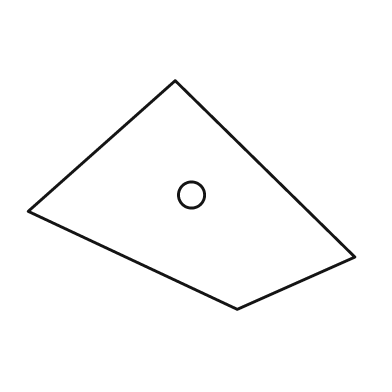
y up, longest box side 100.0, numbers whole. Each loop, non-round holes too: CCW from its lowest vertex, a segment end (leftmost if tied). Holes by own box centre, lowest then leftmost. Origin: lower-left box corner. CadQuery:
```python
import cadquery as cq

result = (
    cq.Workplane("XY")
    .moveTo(64.0, 0.0)
    .lineTo(100.0, 16.0)
    .lineTo(45.0, 70.0)
    .lineTo(0.0, 30.0)
    .close()
    .moveTo(50.0, 35.0)
    .circle(4.0)
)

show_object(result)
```